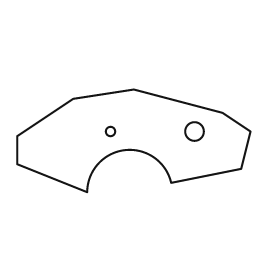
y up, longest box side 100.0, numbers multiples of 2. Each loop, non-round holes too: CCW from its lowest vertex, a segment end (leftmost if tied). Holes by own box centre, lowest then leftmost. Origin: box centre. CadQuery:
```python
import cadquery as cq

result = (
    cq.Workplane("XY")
    .moveTo(-20.0, -22.0)
    .threePointArc((-4.0, -4.0), (16.0, -18.0))
    .lineTo(46.0, -12.0)
    .lineTo(50.0, 4.0)
    .lineTo(38.0, 12.0)
    .lineTo(0.0, 22.0)
    .lineTo(-26.0, 18.0)
    .lineTo(-50.0, 2.0)
    .lineTo(-50.0, -10.0)
    .close()
    .moveTo(-10.0, 4.0)
    .circle(2.0)
    .moveTo(26.0, 4.0)
    .circle(4.0)
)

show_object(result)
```